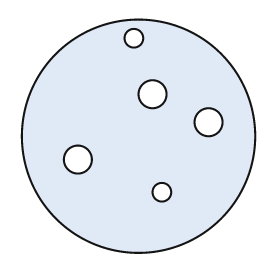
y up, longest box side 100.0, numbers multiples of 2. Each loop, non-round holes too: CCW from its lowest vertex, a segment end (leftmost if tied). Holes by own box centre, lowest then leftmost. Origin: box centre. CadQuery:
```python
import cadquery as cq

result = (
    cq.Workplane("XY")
    .moveTo(0.0, 0.0)
    .circle(50.0)
    .moveTo(10.0, -24.0)
    .circle(4.0)
    .moveTo(-26.0, -10.0)
    .circle(6.0)
    .moveTo(30.0, 6.0)
    .circle(6.0)
    .moveTo(6.0, 18.0)
    .circle(6.0)
    .moveTo(-2.0, 42.0)
    .circle(4.0)
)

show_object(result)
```